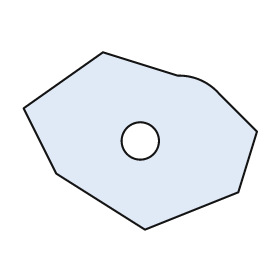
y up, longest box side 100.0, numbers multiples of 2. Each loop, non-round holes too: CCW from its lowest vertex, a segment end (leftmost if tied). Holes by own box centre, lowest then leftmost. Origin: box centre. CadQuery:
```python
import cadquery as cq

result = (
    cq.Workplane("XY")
    .moveTo(2.0, -38.0)
    .lineTo(42.0, -22.0)
    .lineTo(50.0, 4.0)
    .lineTo(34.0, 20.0)
    .threePointArc((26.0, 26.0), (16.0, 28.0))
    .lineTo(-16.0, 38.0)
    .lineTo(-50.0, 14.0)
    .lineTo(-36.0, -14.0)
    .close()
    .moveTo(0.0, 0.0)
    .circle(8.0)
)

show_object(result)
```